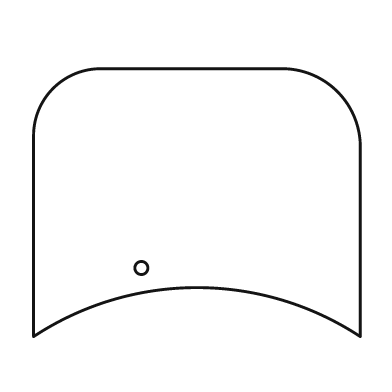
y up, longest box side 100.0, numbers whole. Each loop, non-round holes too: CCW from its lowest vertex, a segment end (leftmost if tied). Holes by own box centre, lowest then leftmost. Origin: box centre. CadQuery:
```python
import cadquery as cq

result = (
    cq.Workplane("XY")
    .moveTo(-50.0, -41.0)
    .threePointArc((0.0, -26.0), (50.0, -41.0))
    .lineTo(50.0, 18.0)
    .threePointArc((43.0, 34.0), (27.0, 41.0))
    .lineTo(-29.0, 41.0)
    .threePointArc((-44.0, 35.0), (-50.0, 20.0))
    .close()
    .moveTo(-17.0, -20.0)
    .circle(2.0)
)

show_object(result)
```